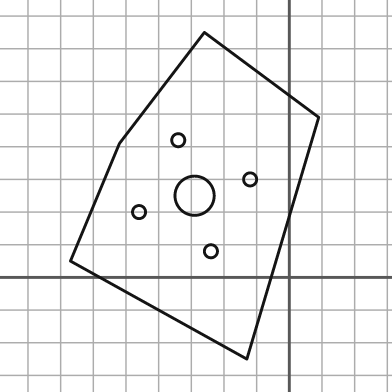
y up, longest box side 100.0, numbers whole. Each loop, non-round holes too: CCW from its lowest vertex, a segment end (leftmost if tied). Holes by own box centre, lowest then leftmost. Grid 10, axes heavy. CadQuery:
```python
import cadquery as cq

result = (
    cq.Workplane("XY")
    .moveTo(-13.0, -25.0)
    .lineTo(9.0, 49.0)
    .lineTo(-26.0, 75.0)
    .lineTo(-52.0, 41.0)
    .lineTo(-67.0, 5.0)
    .close()
    .moveTo(-24.0, 8.0)
    .circle(2.0)
    .moveTo(-46.0, 20.0)
    .circle(2.0)
    .moveTo(-29.0, 25.0)
    .circle(6.0)
    .moveTo(-12.0, 30.0)
    .circle(2.0)
    .moveTo(-34.0, 42.0)
    .circle(2.0)
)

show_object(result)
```